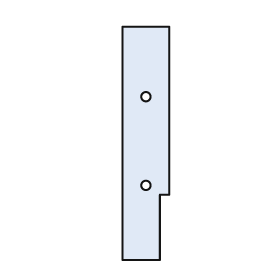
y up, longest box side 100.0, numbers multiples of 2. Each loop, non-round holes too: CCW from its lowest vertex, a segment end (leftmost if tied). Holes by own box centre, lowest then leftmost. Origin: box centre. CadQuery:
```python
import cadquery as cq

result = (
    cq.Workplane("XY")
    .moveTo(-10.0, -50.0)
    .lineTo(6.0, -50.0)
    .lineTo(6.0, -22.0)
    .lineTo(10.0, -22.0)
    .lineTo(10.0, 50.0)
    .lineTo(-10.0, 50.0)
    .close()
    .moveTo(0.0, -18.0)
    .circle(2.0)
    .moveTo(0.0, 20.0)
    .circle(2.0)
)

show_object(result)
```